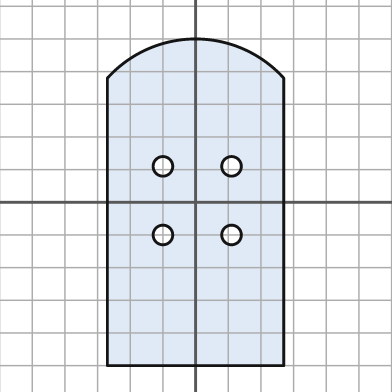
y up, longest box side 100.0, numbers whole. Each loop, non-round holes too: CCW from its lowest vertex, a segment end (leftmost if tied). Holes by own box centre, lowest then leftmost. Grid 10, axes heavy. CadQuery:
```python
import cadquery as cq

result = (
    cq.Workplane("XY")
    .moveTo(-27.0, -50.0)
    .lineTo(27.0, -50.0)
    .lineTo(27.0, 38.0)
    .threePointArc((0.0, 50.0), (-27.0, 38.0))
    .close()
    .moveTo(-10.0, -10.0)
    .circle(3.0)
    .moveTo(11.0, -10.0)
    .circle(3.0)
    .moveTo(-10.0, 11.0)
    .circle(3.0)
    .moveTo(11.0, 11.0)
    .circle(3.0)
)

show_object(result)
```